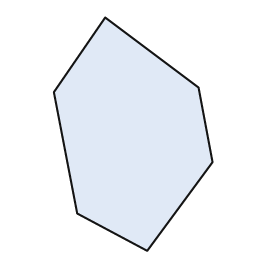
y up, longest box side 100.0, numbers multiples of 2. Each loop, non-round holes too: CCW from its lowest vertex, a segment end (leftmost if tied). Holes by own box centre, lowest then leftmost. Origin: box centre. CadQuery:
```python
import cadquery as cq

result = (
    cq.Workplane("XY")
    .moveTo(6.0, -50.0)
    .lineTo(34.0, -12.0)
    .lineTo(28.0, 20.0)
    .lineTo(-12.0, 50.0)
    .lineTo(-34.0, 18.0)
    .lineTo(-24.0, -34.0)
    .close()
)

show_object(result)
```